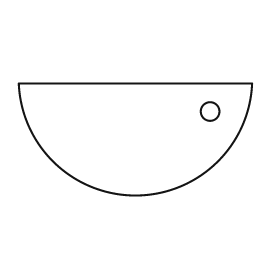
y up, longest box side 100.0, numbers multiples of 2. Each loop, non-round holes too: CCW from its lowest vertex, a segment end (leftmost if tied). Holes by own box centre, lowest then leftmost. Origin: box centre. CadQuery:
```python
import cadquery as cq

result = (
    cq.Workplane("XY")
    .moveTo(-50.0, 24.0)
    .threePointArc((0.0, -24.0), (50.0, 24.0))
    .close()
    .moveTo(32.0, 12.0)
    .circle(4.0)
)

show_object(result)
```